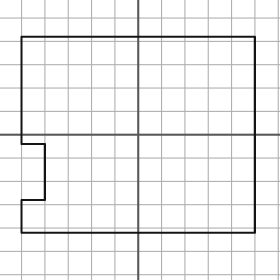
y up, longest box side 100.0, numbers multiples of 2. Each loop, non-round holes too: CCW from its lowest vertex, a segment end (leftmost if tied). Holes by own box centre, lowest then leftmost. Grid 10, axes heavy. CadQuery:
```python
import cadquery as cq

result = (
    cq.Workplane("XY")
    .moveTo(-50.0, -42.0)
    .lineTo(50.0, -42.0)
    .lineTo(50.0, 42.0)
    .lineTo(-50.0, 42.0)
    .lineTo(-50.0, -4.0)
    .lineTo(-40.0, -4.0)
    .lineTo(-40.0, -28.0)
    .lineTo(-50.0, -28.0)
    .close()
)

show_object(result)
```